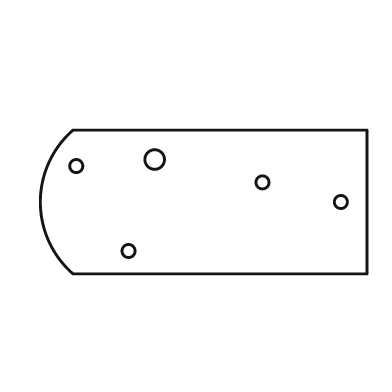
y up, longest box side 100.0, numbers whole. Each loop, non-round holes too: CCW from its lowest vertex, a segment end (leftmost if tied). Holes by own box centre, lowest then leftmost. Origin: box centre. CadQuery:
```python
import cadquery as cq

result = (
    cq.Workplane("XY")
    .moveTo(-40.0, -22.0)
    .lineTo(50.0, -22.0)
    .lineTo(50.0, 22.0)
    .lineTo(-40.0, 22.0)
    .threePointArc((-50.0, 0.0), (-40.0, -22.0))
    .close()
    .moveTo(-23.0, -15.0)
    .circle(2.0)
    .moveTo(42.0, 0.0)
    .circle(2.0)
    .moveTo(18.0, 6.0)
    .circle(2.0)
    .moveTo(-39.0, 11.0)
    .circle(2.0)
    .moveTo(-15.0, 13.0)
    .circle(3.0)
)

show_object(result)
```